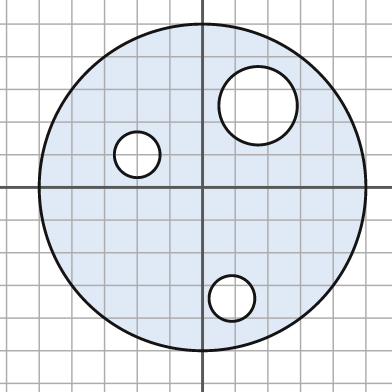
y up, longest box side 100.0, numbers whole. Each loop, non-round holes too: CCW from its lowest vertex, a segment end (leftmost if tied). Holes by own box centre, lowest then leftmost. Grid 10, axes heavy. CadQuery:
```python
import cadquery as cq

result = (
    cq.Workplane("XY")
    .moveTo(0.0, 0.0)
    .circle(50.0)
    .moveTo(9.0, -34.0)
    .circle(7.0)
    .moveTo(-20.0, 10.0)
    .circle(7.0)
    .moveTo(17.0, 25.0)
    .circle(12.0)
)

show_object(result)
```